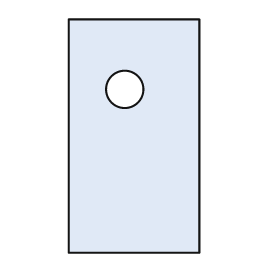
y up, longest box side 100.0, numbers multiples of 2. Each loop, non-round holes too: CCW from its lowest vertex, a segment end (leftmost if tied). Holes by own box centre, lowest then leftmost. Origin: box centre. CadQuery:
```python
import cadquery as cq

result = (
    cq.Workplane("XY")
    .moveTo(-28.0, -50.0)
    .lineTo(28.0, -50.0)
    .lineTo(28.0, 50.0)
    .lineTo(-28.0, 50.0)
    .close()
    .moveTo(-4.0, 20.0)
    .circle(8.0)
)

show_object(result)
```